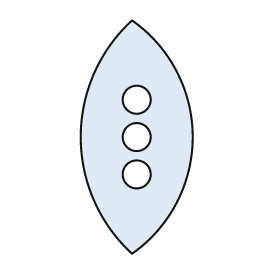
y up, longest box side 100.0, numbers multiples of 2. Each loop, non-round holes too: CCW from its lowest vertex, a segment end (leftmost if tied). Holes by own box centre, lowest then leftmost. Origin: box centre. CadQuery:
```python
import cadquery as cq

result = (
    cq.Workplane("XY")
    .moveTo(-2.0, -50.0)
    .threePointArc((24.0, 0.0), (-2.0, 50.0))
    .threePointArc((-24.0, 0.0), (-2.0, -50.0))
    .close()
    .moveTo(0.0, -16.0)
    .circle(6.0)
    .moveTo(0.0, 0.0)
    .circle(6.0)
    .moveTo(0.0, 16.0)
    .circle(6.0)
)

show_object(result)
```